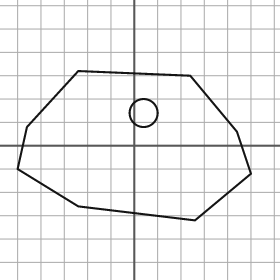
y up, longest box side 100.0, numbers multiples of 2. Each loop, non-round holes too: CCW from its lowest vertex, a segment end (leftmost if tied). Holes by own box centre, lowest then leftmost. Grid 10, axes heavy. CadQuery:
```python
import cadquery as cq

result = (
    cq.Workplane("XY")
    .moveTo(26.0, -32.0)
    .lineTo(50.0, -12.0)
    .lineTo(44.0, 6.0)
    .lineTo(24.0, 30.0)
    .lineTo(-24.0, 32.0)
    .lineTo(-46.0, 8.0)
    .lineTo(-50.0, -10.0)
    .lineTo(-24.0, -26.0)
    .close()
    .moveTo(4.0, 14.0)
    .circle(6.0)
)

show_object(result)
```